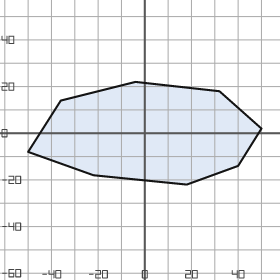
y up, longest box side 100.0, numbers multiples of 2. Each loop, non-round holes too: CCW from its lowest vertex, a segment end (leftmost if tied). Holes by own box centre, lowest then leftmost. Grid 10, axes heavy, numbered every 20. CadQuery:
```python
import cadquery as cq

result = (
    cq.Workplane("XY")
    .moveTo(18.0, -22.0)
    .lineTo(40.0, -14.0)
    .lineTo(50.0, 2.0)
    .lineTo(32.0, 18.0)
    .lineTo(-4.0, 22.0)
    .lineTo(-36.0, 14.0)
    .lineTo(-50.0, -8.0)
    .lineTo(-22.0, -18.0)
    .close()
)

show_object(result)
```